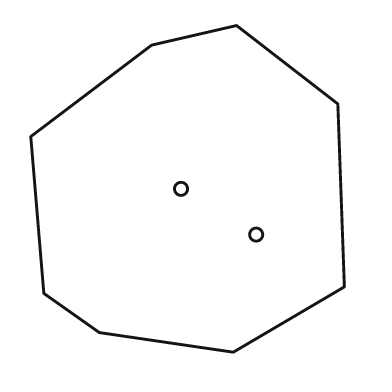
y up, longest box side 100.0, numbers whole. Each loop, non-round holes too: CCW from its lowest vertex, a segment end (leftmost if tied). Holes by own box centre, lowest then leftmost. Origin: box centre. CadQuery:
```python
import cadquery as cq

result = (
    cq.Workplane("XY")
    .moveTo(14.0, -50.0)
    .lineTo(48.0, -30.0)
    .lineTo(46.0, 26.0)
    .lineTo(15.0, 50.0)
    .lineTo(-11.0, 44.0)
    .lineTo(-48.0, 16.0)
    .lineTo(-44.0, -32.0)
    .lineTo(-27.0, -44.0)
    .close()
    .moveTo(21.0, -14.0)
    .circle(2.0)
    .moveTo(-2.0, 0.0)
    .circle(2.0)
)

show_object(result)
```